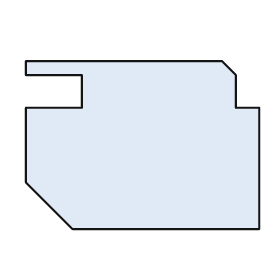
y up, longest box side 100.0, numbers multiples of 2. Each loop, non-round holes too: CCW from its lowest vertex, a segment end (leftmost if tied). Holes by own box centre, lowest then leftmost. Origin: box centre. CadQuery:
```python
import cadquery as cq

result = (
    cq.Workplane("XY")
    .moveTo(-30.0, -36.0)
    .lineTo(50.0, -36.0)
    .lineTo(50.0, 16.0)
    .lineTo(40.0, 16.0)
    .lineTo(40.0, 30.0)
    .lineTo(34.0, 36.0)
    .lineTo(-50.0, 36.0)
    .lineTo(-50.0, 30.0)
    .lineTo(-26.0, 30.0)
    .lineTo(-26.0, 16.0)
    .lineTo(-50.0, 16.0)
    .lineTo(-50.0, -16.0)
    .close()
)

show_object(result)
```